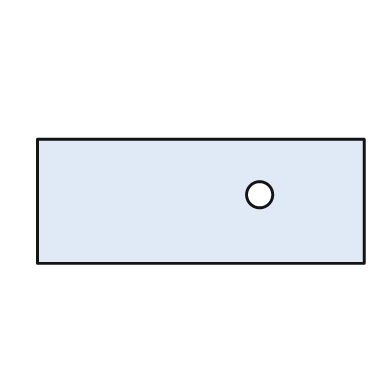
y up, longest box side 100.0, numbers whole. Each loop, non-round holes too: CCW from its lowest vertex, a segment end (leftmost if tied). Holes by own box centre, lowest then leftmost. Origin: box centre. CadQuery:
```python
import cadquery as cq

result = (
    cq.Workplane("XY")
    .moveTo(-50.0, -19.0)
    .lineTo(50.0, -19.0)
    .lineTo(50.0, 19.0)
    .lineTo(-50.0, 19.0)
    .close()
    .moveTo(18.0, 2.0)
    .circle(4.0)
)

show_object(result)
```